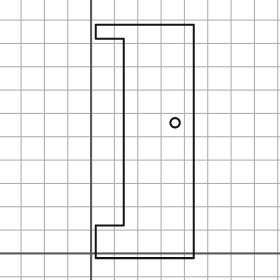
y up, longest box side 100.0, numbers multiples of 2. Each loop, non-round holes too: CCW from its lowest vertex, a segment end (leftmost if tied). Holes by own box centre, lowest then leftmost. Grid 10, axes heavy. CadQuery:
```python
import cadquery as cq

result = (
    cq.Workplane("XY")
    .moveTo(2.0, -2.0)
    .lineTo(44.0, -2.0)
    .lineTo(44.0, 98.0)
    .lineTo(2.0, 98.0)
    .lineTo(2.0, 92.0)
    .lineTo(14.0, 92.0)
    .lineTo(14.0, 12.0)
    .lineTo(2.0, 12.0)
    .close()
    .moveTo(36.0, 56.0)
    .circle(2.0)
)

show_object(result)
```